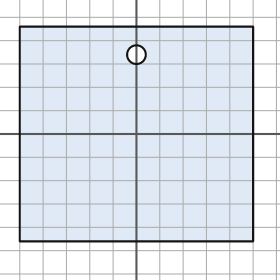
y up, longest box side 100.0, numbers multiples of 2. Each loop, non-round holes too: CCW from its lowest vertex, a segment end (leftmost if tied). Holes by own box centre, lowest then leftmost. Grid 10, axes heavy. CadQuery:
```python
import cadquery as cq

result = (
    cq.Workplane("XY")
    .moveTo(-50.0, -46.0)
    .lineTo(50.0, -46.0)
    .lineTo(50.0, 46.0)
    .lineTo(-50.0, 46.0)
    .close()
    .moveTo(0.0, 34.0)
    .circle(4.0)
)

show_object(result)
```